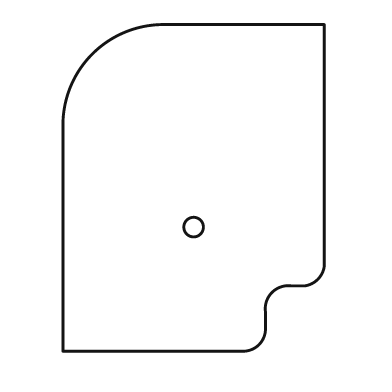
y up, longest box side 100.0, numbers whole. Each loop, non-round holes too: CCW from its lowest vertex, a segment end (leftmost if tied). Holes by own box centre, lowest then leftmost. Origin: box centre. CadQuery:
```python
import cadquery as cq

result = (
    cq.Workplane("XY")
    .moveTo(-40.0, -50.0)
    .lineTo(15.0, -50.0)
    .threePointArc((20.0, -48.0), (22.0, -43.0))
    .lineTo(22.0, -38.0)
    .threePointArc((24.0, -32.0), (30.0, -30.0))
    .lineTo(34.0, -30.0)
    .threePointArc((38.0, -28.0), (40.0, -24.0))
    .lineTo(40.0, 50.0)
    .lineTo(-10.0, 50.0)
    .threePointArc((-31.0, 41.0), (-40.0, 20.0))
    .close()
    .moveTo(0.0, -12.0)
    .circle(3.0)
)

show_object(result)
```